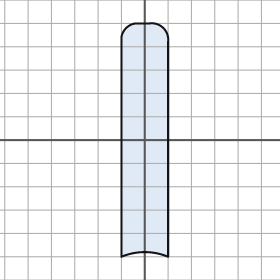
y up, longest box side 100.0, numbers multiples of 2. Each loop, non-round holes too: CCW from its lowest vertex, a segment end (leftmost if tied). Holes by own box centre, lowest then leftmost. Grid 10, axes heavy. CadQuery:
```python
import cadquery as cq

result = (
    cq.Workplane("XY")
    .moveTo(-10.0, -50.0)
    .threePointArc((0.0, -48.0), (10.0, -50.0))
    .lineTo(10.0, 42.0)
    .threePointArc((8.0, 48.0), (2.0, 50.0))
    .lineTo(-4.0, 50.0)
    .threePointArc((-8.0, 48.0), (-10.0, 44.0))
    .close()
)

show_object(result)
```